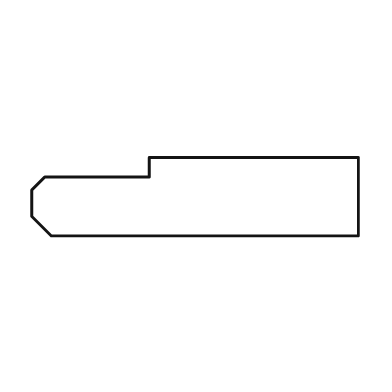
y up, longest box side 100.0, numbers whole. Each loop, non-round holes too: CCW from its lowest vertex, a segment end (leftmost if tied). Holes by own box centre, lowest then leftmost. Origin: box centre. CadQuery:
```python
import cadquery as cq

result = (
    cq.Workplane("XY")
    .moveTo(-44.0, -12.0)
    .lineTo(50.0, -12.0)
    .lineTo(50.0, 12.0)
    .lineTo(-14.0, 12.0)
    .lineTo(-14.0, 6.0)
    .lineTo(-46.0, 6.0)
    .lineTo(-50.0, 2.0)
    .lineTo(-50.0, -6.0)
    .close()
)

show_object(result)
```